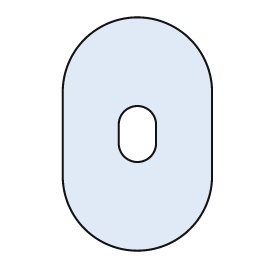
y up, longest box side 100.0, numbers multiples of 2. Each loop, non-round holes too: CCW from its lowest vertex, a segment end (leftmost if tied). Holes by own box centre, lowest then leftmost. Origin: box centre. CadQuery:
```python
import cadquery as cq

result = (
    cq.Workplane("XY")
    .moveTo(-32.0, -18.0)
    .threePointArc((0.0, -50.0), (32.0, -18.0))
    .lineTo(32.0, 18.0)
    .threePointArc((0.0, 50.0), (-32.0, 18.0))
    .close()
    .moveTo(-8.0, -4.0)
    .threePointArc((0.0, -12.0), (8.0, -4.0))
    .lineTo(8.0, 4.0)
    .threePointArc((0.0, 12.0), (-8.0, 4.0))
    .close()
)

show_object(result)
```